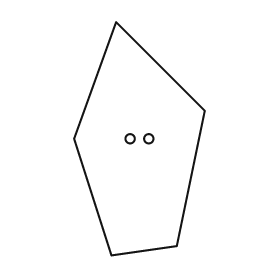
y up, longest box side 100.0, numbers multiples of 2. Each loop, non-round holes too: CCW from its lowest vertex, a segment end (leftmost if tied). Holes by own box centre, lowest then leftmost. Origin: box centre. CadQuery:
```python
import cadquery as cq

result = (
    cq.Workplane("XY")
    .moveTo(-12.0, -50.0)
    .lineTo(16.0, -46.0)
    .lineTo(28.0, 12.0)
    .lineTo(-10.0, 50.0)
    .lineTo(-28.0, 0.0)
    .close()
    .moveTo(-4.0, 0.0)
    .circle(2.0)
    .moveTo(4.0, 0.0)
    .circle(2.0)
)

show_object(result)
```